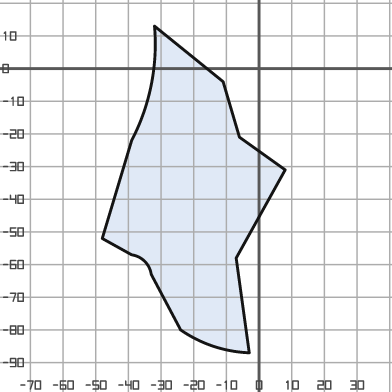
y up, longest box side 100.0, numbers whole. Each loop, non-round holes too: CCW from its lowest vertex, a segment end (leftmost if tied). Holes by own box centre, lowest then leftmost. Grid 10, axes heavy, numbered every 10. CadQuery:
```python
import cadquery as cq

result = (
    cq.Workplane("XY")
    .moveTo(-3.0, -87.0)
    .lineTo(-7.0, -58.0)
    .lineTo(8.0, -31.0)
    .lineTo(-6.0, -21.0)
    .lineTo(-11.0, -4.0)
    .lineTo(-32.0, 13.0)
    .threePointArc((-33.0, -5.0), (-39.0, -22.0))
    .lineTo(-48.0, -52.0)
    .lineTo(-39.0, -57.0)
    .threePointArc((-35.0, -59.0), (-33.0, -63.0))
    .lineTo(-24.0, -80.0)
    .threePointArc((-14.0, -85.0), (-3.0, -87.0))
    .close()
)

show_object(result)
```